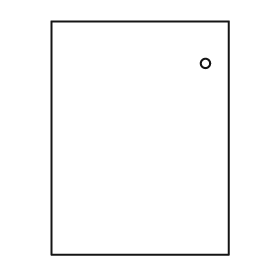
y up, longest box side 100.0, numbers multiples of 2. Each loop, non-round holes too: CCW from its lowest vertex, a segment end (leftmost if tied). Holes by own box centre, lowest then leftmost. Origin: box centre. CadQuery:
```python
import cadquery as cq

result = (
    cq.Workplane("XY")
    .moveTo(-38.0, -50.0)
    .lineTo(38.0, -50.0)
    .lineTo(38.0, 50.0)
    .lineTo(-38.0, 50.0)
    .close()
    .moveTo(28.0, 32.0)
    .circle(2.0)
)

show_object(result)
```